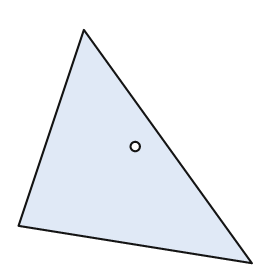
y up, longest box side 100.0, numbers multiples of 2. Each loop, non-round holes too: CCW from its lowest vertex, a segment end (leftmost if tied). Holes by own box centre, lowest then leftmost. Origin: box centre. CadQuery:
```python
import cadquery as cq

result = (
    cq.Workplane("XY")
    .moveTo(50.0, -50.0)
    .lineTo(-22.0, 50.0)
    .lineTo(-50.0, -34.0)
    .close()
    .moveTo(0.0, 0.0)
    .circle(2.0)
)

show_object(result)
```